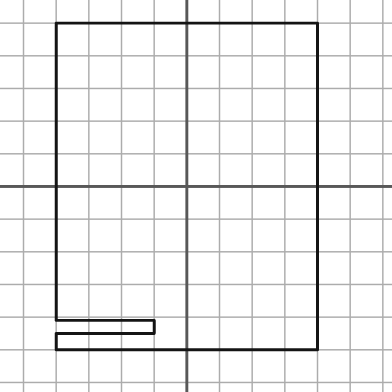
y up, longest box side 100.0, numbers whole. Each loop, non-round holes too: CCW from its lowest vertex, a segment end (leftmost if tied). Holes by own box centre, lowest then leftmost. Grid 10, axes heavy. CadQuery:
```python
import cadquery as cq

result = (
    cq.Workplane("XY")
    .moveTo(-40.0, -50.0)
    .lineTo(40.0, -50.0)
    .lineTo(40.0, 50.0)
    .lineTo(-40.0, 50.0)
    .lineTo(-40.0, -41.0)
    .lineTo(-10.0, -41.0)
    .lineTo(-10.0, -45.0)
    .lineTo(-40.0, -45.0)
    .close()
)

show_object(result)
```